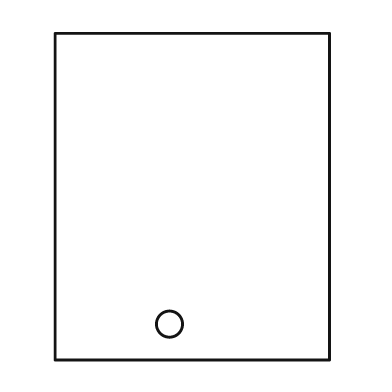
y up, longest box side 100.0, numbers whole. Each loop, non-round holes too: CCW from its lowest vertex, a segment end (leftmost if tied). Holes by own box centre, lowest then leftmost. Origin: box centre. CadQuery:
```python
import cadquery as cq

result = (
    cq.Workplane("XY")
    .moveTo(-42.0, -50.0)
    .lineTo(42.0, -50.0)
    .lineTo(42.0, 50.0)
    .lineTo(-42.0, 50.0)
    .close()
    .moveTo(-7.0, -39.0)
    .circle(4.0)
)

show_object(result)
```